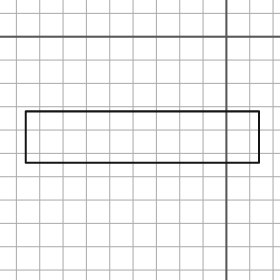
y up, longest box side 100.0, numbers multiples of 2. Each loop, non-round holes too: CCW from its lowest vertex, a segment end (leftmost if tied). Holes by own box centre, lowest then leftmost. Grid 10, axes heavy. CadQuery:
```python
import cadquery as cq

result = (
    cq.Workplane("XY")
    .moveTo(-86.0, -54.0)
    .lineTo(14.0, -54.0)
    .lineTo(14.0, -32.0)
    .lineTo(-86.0, -32.0)
    .close()
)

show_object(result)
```